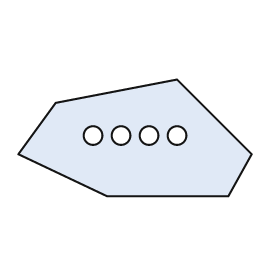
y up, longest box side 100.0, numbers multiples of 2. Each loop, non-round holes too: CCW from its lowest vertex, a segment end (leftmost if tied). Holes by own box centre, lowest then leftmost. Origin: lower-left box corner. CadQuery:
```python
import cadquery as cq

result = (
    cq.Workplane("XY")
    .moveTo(38.0, 0.0)
    .lineTo(90.0, 0.0)
    .lineTo(100.0, 18.0)
    .lineTo(68.0, 50.0)
    .lineTo(16.0, 40.0)
    .lineTo(0.0, 18.0)
    .close()
    .moveTo(32.0, 26.0)
    .circle(4.0)
    .moveTo(44.0, 26.0)
    .circle(4.0)
    .moveTo(56.0, 26.0)
    .circle(4.0)
    .moveTo(68.0, 26.0)
    .circle(4.0)
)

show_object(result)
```